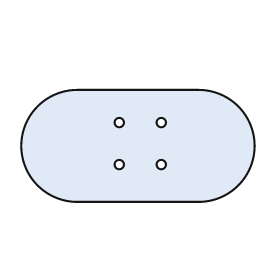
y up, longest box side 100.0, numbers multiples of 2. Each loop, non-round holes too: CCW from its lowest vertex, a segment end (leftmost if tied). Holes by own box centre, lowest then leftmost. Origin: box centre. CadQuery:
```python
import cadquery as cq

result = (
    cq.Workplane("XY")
    .moveTo(-26.0, -24.0)
    .lineTo(26.0, -24.0)
    .threePointArc((50.0, 0.0), (26.0, 24.0))
    .lineTo(-26.0, 24.0)
    .threePointArc((-50.0, 0.0), (-26.0, -24.0))
    .close()
    .moveTo(-8.0, -8.0)
    .circle(2.0)
    .moveTo(10.0, -8.0)
    .circle(2.0)
    .moveTo(-8.0, 10.0)
    .circle(2.0)
    .moveTo(10.0, 10.0)
    .circle(2.0)
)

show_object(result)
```